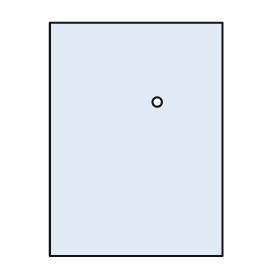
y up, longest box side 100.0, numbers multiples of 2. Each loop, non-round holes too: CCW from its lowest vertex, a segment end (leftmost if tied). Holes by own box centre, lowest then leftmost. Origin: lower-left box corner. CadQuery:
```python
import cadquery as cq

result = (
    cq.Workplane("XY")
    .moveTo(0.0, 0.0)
    .lineTo(74.0, 0.0)
    .lineTo(74.0, 100.0)
    .lineTo(0.0, 100.0)
    .close()
    .moveTo(46.0, 66.0)
    .circle(2.0)
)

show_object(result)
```